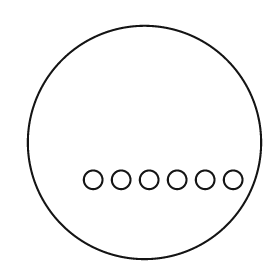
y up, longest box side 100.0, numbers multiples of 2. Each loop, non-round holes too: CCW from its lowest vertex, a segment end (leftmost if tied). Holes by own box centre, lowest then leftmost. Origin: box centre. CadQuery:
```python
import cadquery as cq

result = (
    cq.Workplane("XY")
    .moveTo(0.0, 0.0)
    .circle(50.0)
    .moveTo(-22.0, -16.0)
    .circle(4.0)
    .moveTo(-10.0, -16.0)
    .circle(4.0)
    .moveTo(2.0, -16.0)
    .circle(4.0)
    .moveTo(14.0, -16.0)
    .circle(4.0)
    .moveTo(26.0, -16.0)
    .circle(4.0)
    .moveTo(38.0, -16.0)
    .circle(4.0)
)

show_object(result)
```